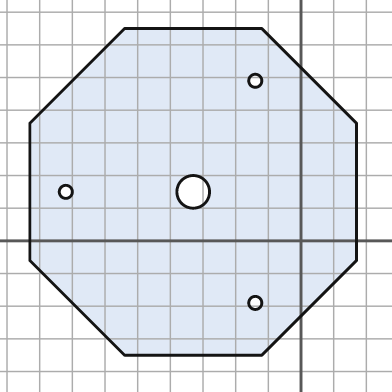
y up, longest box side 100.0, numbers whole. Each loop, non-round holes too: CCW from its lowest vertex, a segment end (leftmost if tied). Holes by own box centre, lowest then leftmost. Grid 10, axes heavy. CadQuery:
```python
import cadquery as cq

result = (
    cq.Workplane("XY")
    .moveTo(-54.0, -35.0)
    .lineTo(-12.0, -35.0)
    .lineTo(17.0, -6.0)
    .lineTo(17.0, 36.0)
    .lineTo(-12.0, 65.0)
    .lineTo(-54.0, 65.0)
    .lineTo(-83.0, 36.0)
    .lineTo(-83.0, -6.0)
    .close()
    .moveTo(-14.0, -19.0)
    .circle(2.0)
    .moveTo(-72.0, 15.0)
    .circle(2.0)
    .moveTo(-33.0, 15.0)
    .circle(5.0)
    .moveTo(-14.0, 49.0)
    .circle(2.0)
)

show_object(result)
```